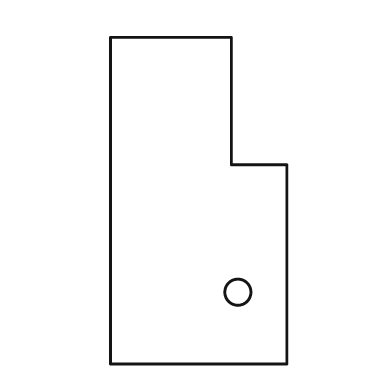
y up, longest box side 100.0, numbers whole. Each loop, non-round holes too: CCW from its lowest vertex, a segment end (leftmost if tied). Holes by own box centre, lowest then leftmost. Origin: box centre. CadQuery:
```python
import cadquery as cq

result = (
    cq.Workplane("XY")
    .moveTo(-27.0, -50.0)
    .lineTo(27.0, -50.0)
    .lineTo(27.0, 11.0)
    .lineTo(10.0, 11.0)
    .lineTo(10.0, 50.0)
    .lineTo(-27.0, 50.0)
    .close()
    .moveTo(12.0, -28.0)
    .circle(4.0)
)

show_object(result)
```